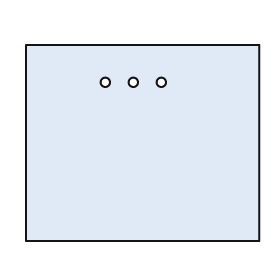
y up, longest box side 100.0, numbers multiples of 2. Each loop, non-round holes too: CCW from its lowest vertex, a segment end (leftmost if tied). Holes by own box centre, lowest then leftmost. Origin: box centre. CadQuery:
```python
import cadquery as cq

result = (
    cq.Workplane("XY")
    .moveTo(-50.0, -42.0)
    .lineTo(50.0, -42.0)
    .lineTo(50.0, 42.0)
    .lineTo(-50.0, 42.0)
    .close()
    .moveTo(-16.0, 26.0)
    .circle(2.0)
    .moveTo(-4.0, 26.0)
    .circle(2.0)
    .moveTo(8.0, 26.0)
    .circle(2.0)
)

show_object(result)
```